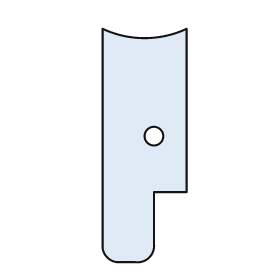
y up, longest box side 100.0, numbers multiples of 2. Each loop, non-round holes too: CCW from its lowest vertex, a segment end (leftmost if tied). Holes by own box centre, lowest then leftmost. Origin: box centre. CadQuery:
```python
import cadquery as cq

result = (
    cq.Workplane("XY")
    .moveTo(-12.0, -50.0)
    .lineTo(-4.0, -50.0)
    .threePointArc((2.0, -48.0), (4.0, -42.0))
    .lineTo(4.0, -20.0)
    .lineTo(18.0, -20.0)
    .lineTo(18.0, 50.0)
    .threePointArc((0.0, 46.0), (-18.0, 50.0))
    .lineTo(-18.0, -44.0)
    .threePointArc((-16.0, -48.0), (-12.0, -50.0))
    .close()
    .moveTo(4.0, 4.0)
    .circle(4.0)
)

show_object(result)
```